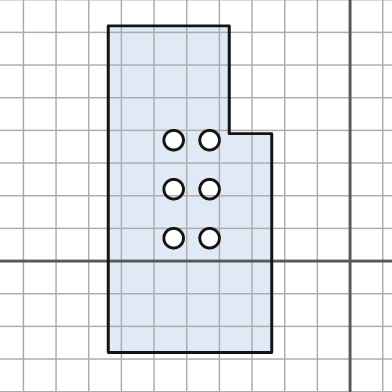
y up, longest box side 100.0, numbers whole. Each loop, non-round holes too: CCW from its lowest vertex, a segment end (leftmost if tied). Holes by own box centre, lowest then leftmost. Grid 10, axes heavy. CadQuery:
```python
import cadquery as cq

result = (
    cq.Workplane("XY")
    .moveTo(-74.0, -28.0)
    .lineTo(-24.0, -28.0)
    .lineTo(-24.0, 39.0)
    .lineTo(-37.0, 39.0)
    .lineTo(-37.0, 72.0)
    .lineTo(-74.0, 72.0)
    .close()
    .moveTo(-54.0, 7.0)
    .circle(3.0)
    .moveTo(-43.0, 7.0)
    .circle(3.0)
    .moveTo(-54.0, 22.0)
    .circle(3.0)
    .moveTo(-43.0, 22.0)
    .circle(3.0)
    .moveTo(-54.0, 37.0)
    .circle(3.0)
    .moveTo(-43.0, 37.0)
    .circle(3.0)
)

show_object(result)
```